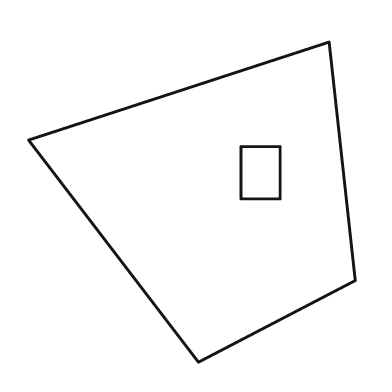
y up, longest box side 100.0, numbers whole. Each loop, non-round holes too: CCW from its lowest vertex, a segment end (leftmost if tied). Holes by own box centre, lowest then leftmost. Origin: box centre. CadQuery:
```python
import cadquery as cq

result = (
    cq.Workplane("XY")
    .moveTo(2.0, -49.0)
    .lineTo(50.0, -24.0)
    .lineTo(42.0, 49.0)
    .lineTo(-50.0, 19.0)
    .close()
    .moveTo(15.0, 1.0)
    .lineTo(27.0, 1.0)
    .lineTo(27.0, 17.0)
    .lineTo(15.0, 17.0)
    .close()
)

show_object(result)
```